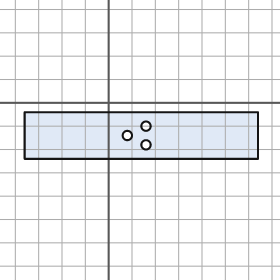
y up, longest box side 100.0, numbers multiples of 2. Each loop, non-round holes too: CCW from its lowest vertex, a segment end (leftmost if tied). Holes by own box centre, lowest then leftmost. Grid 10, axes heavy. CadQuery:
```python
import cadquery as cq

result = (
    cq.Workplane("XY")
    .moveTo(-36.0, -24.0)
    .lineTo(64.0, -24.0)
    .lineTo(64.0, -4.0)
    .lineTo(-36.0, -4.0)
    .close()
    .moveTo(16.0, -18.0)
    .circle(2.0)
    .moveTo(8.0, -14.0)
    .circle(2.0)
    .moveTo(16.0, -10.0)
    .circle(2.0)
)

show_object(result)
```